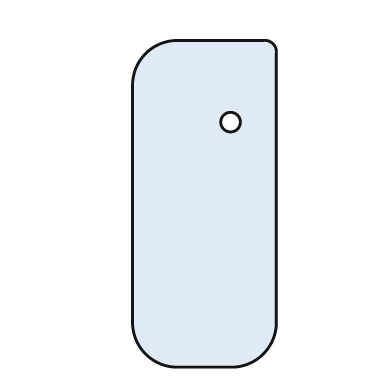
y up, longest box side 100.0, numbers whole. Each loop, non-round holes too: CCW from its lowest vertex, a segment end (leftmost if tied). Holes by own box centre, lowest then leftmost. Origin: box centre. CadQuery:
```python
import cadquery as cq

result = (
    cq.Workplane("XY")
    .moveTo(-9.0, -50.0)
    .lineTo(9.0, -50.0)
    .threePointArc((18.0, -46.0), (22.0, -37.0))
    .lineTo(22.0, 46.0)
    .threePointArc((21.0, 49.0), (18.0, 50.0))
    .lineTo(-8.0, 50.0)
    .threePointArc((-18.0, 46.0), (-22.0, 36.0))
    .lineTo(-22.0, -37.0)
    .threePointArc((-18.0, -46.0), (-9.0, -50.0))
    .close()
    .moveTo(8.0, 25.0)
    .circle(3.0)
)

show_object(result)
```